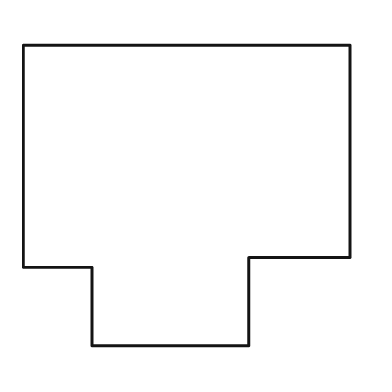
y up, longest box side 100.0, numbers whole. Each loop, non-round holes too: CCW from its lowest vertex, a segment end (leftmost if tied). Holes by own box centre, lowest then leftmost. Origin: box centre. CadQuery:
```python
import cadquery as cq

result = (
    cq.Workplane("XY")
    .moveTo(-29.0, -46.0)
    .lineTo(19.0, -46.0)
    .lineTo(19.0, -19.0)
    .lineTo(50.0, -19.0)
    .lineTo(50.0, 46.0)
    .lineTo(-50.0, 46.0)
    .lineTo(-50.0, -22.0)
    .lineTo(-29.0, -22.0)
    .close()
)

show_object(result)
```